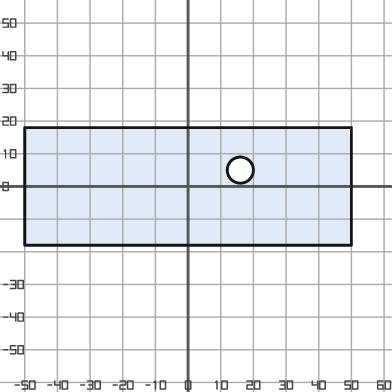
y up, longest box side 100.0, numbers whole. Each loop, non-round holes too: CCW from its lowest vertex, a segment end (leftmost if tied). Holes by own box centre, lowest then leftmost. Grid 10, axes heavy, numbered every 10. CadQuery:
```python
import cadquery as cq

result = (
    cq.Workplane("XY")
    .moveTo(-50.0, -18.0)
    .lineTo(50.0, -18.0)
    .lineTo(50.0, 18.0)
    .lineTo(-50.0, 18.0)
    .close()
    .moveTo(16.0, 5.0)
    .circle(4.0)
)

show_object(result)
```